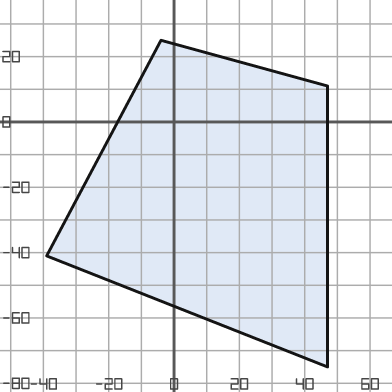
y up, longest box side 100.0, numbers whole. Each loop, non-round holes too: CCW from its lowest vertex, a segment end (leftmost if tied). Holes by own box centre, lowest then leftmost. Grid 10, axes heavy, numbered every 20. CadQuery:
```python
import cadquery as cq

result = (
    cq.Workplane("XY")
    .moveTo(47.0, -75.0)
    .lineTo(47.0, 11.0)
    .lineTo(-4.0, 25.0)
    .lineTo(-39.0, -41.0)
    .close()
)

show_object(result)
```